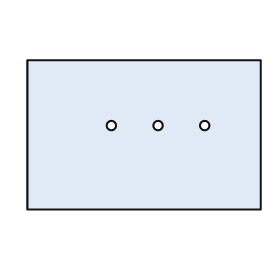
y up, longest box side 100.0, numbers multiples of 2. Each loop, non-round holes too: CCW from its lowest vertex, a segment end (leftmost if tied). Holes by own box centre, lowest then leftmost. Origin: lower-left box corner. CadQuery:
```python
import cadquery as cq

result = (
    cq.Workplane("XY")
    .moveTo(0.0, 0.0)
    .lineTo(100.0, 0.0)
    .lineTo(100.0, 64.0)
    .lineTo(0.0, 64.0)
    .close()
    .moveTo(36.0, 36.0)
    .circle(2.0)
    .moveTo(56.0, 36.0)
    .circle(2.0)
    .moveTo(76.0, 36.0)
    .circle(2.0)
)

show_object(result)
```